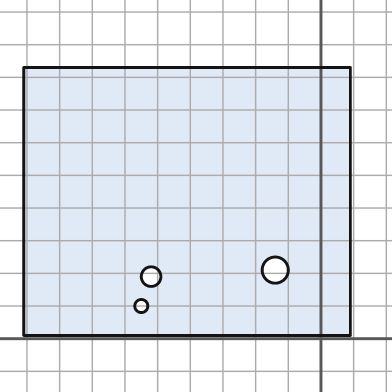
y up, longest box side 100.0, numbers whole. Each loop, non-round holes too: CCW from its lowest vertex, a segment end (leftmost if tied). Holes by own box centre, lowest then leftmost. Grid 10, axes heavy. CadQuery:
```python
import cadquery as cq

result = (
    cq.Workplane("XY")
    .moveTo(-91.0, 1.0)
    .lineTo(9.0, 1.0)
    .lineTo(9.0, 83.0)
    .lineTo(-91.0, 83.0)
    .close()
    .moveTo(-55.0, 10.0)
    .circle(2.0)
    .moveTo(-52.0, 19.0)
    .circle(3.0)
    .moveTo(-14.0, 21.0)
    .circle(4.0)
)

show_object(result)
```